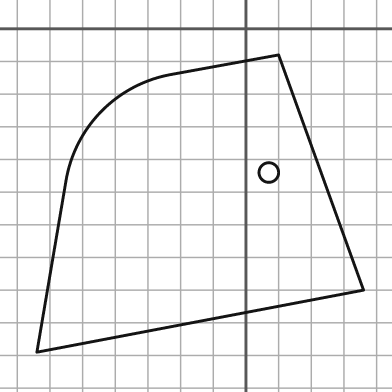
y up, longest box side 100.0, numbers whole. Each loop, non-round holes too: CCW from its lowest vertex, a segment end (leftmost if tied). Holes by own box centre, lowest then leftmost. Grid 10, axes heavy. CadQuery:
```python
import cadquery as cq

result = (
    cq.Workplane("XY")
    .moveTo(-64.0, -99.0)
    .lineTo(36.0, -80.0)
    .lineTo(10.0, -8.0)
    .lineTo(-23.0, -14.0)
    .threePointArc((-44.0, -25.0), (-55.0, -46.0))
    .close()
    .moveTo(7.0, -44.0)
    .circle(3.0)
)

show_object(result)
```